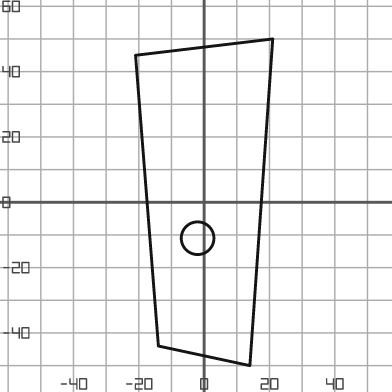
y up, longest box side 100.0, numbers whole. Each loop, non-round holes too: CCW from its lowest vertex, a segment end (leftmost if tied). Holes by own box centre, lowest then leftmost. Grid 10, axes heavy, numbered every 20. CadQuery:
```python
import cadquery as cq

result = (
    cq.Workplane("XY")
    .moveTo(14.0, -50.0)
    .lineTo(21.0, 50.0)
    .lineTo(-21.0, 45.0)
    .lineTo(-14.0, -44.0)
    .close()
    .moveTo(-2.0, -11.0)
    .circle(5.0)
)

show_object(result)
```